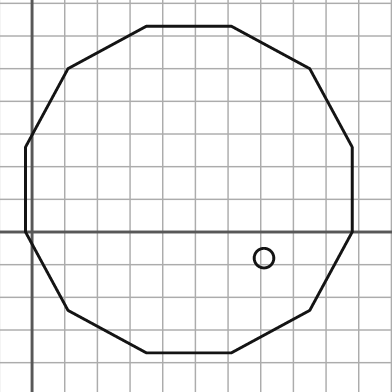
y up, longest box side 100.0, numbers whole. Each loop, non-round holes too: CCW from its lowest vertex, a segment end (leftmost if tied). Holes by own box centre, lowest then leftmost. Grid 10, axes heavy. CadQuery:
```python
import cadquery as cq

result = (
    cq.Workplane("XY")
    .moveTo(35.0, -37.0)
    .lineTo(61.0, -37.0)
    .lineTo(85.0, -24.0)
    .lineTo(98.0, 0.0)
    .lineTo(98.0, 26.0)
    .lineTo(85.0, 50.0)
    .lineTo(61.0, 63.0)
    .lineTo(35.0, 63.0)
    .lineTo(11.0, 50.0)
    .lineTo(-2.0, 26.0)
    .lineTo(-2.0, 0.0)
    .lineTo(11.0, -24.0)
    .close()
    .moveTo(71.0, -8.0)
    .circle(3.0)
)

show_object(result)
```